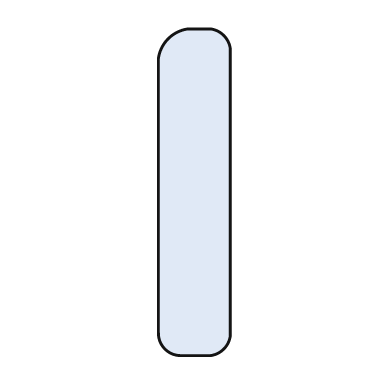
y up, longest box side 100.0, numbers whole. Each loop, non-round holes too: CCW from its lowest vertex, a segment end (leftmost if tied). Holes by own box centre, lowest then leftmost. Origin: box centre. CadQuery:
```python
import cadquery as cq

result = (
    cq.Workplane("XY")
    .moveTo(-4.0, -50.0)
    .lineTo(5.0, -50.0)
    .threePointArc((9.0, -48.0), (11.0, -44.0))
    .lineTo(11.0, 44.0)
    .threePointArc((9.0, 48.0), (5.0, 50.0))
    .lineTo(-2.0, 50.0)
    .threePointArc((-8.0, 47.0), (-11.0, 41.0))
    .lineTo(-11.0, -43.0)
    .threePointArc((-9.0, -48.0), (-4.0, -50.0))
    .close()
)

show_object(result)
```